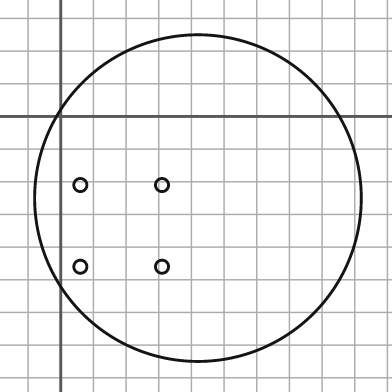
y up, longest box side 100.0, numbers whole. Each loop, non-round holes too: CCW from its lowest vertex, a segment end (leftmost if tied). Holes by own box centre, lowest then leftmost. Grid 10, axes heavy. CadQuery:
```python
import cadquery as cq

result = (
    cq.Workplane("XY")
    .moveTo(42.0, -25.0)
    .circle(50.0)
    .moveTo(6.0, -46.0)
    .circle(2.0)
    .moveTo(31.0, -46.0)
    .circle(2.0)
    .moveTo(6.0, -21.0)
    .circle(2.0)
    .moveTo(31.0, -21.0)
    .circle(2.0)
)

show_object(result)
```